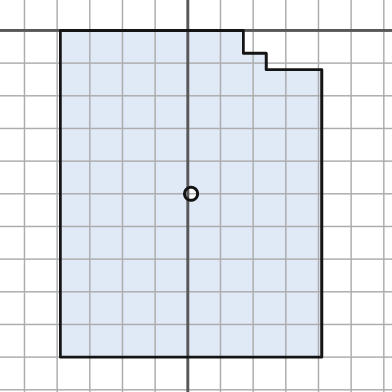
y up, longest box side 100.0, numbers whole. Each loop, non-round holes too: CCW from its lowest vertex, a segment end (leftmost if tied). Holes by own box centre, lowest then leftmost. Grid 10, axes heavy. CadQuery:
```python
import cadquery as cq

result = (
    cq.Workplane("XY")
    .moveTo(-39.0, -100.0)
    .lineTo(41.0, -100.0)
    .lineTo(41.0, -12.0)
    .lineTo(24.0, -12.0)
    .lineTo(24.0, -7.0)
    .lineTo(17.0, -7.0)
    .lineTo(17.0, 0.0)
    .lineTo(-39.0, 0.0)
    .close()
    .moveTo(1.0, -50.0)
    .circle(2.0)
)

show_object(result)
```